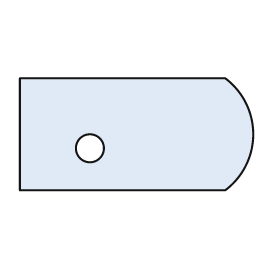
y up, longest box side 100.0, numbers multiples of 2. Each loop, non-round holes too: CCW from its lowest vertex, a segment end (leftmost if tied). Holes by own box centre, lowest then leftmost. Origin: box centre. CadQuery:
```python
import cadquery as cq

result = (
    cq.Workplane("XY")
    .moveTo(-50.0, -24.0)
    .lineTo(38.0, -24.0)
    .threePointArc((50.0, 0.0), (38.0, 24.0))
    .lineTo(-50.0, 24.0)
    .close()
    .moveTo(-20.0, -6.0)
    .circle(6.0)
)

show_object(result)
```